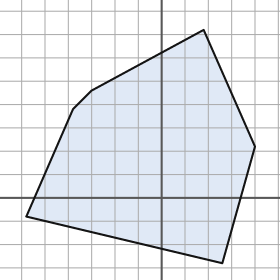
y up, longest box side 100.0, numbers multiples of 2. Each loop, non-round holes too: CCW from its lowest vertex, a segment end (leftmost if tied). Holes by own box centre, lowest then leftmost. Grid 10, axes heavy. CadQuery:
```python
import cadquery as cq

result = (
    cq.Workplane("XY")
    .moveTo(26.0, -28.0)
    .lineTo(40.0, 22.0)
    .lineTo(18.0, 72.0)
    .lineTo(-30.0, 46.0)
    .lineTo(-38.0, 38.0)
    .lineTo(-58.0, -8.0)
    .close()
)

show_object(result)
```